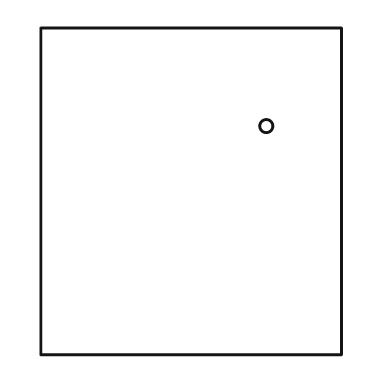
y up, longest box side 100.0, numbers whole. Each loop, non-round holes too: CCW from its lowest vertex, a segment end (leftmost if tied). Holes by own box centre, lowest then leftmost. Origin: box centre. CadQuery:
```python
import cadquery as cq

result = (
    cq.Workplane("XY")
    .moveTo(-46.0, -50.0)
    .lineTo(46.0, -50.0)
    .lineTo(46.0, 50.0)
    .lineTo(-46.0, 50.0)
    .close()
    .moveTo(23.0, 20.0)
    .circle(2.0)
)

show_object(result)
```